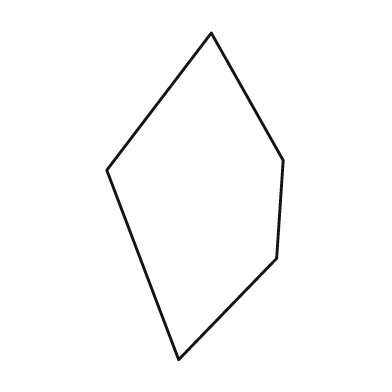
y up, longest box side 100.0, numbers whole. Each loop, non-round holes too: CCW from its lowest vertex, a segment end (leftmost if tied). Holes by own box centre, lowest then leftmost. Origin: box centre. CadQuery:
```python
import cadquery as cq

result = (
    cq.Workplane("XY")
    .moveTo(-5.0, -50.0)
    .lineTo(25.0, -19.0)
    .lineTo(27.0, 11.0)
    .lineTo(5.0, 50.0)
    .lineTo(-27.0, 8.0)
    .close()
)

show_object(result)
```